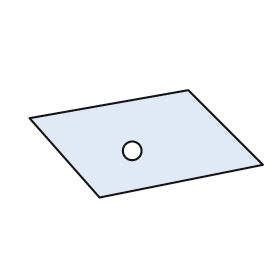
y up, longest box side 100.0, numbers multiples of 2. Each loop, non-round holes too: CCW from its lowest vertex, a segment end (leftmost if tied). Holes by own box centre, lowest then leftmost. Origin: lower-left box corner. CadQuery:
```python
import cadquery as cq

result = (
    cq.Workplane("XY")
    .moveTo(30.0, 0.0)
    .lineTo(100.0, 14.0)
    .lineTo(68.0, 46.0)
    .lineTo(0.0, 34.0)
    .close()
    .moveTo(44.0, 20.0)
    .circle(4.0)
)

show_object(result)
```